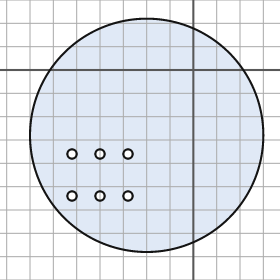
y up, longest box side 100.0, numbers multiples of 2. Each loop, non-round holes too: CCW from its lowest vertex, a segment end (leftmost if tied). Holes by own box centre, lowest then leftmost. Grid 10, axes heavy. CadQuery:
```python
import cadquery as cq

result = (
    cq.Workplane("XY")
    .moveTo(-20.0, -28.0)
    .circle(50.0)
    .moveTo(-52.0, -54.0)
    .circle(2.0)
    .moveTo(-40.0, -54.0)
    .circle(2.0)
    .moveTo(-28.0, -54.0)
    .circle(2.0)
    .moveTo(-52.0, -36.0)
    .circle(2.0)
    .moveTo(-40.0, -36.0)
    .circle(2.0)
    .moveTo(-28.0, -36.0)
    .circle(2.0)
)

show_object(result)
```